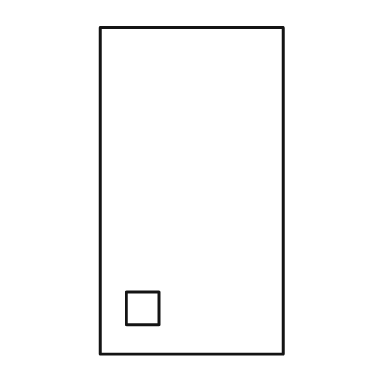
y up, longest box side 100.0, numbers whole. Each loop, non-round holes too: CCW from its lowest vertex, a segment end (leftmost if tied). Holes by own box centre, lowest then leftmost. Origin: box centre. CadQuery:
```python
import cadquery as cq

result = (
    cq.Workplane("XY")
    .moveTo(-28.0, -50.0)
    .lineTo(28.0, -50.0)
    .lineTo(28.0, 50.0)
    .lineTo(-28.0, 50.0)
    .close()
    .moveTo(-20.0, -41.0)
    .lineTo(-10.0, -41.0)
    .lineTo(-10.0, -31.0)
    .lineTo(-20.0, -31.0)
    .close()
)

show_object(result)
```